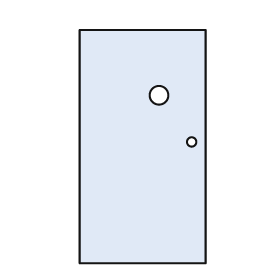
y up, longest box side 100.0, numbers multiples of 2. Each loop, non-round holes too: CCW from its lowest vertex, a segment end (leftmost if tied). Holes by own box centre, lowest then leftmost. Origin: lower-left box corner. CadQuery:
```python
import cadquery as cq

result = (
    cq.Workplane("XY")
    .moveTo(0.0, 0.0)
    .lineTo(54.0, 0.0)
    .lineTo(54.0, 100.0)
    .lineTo(0.0, 100.0)
    .close()
    .moveTo(48.0, 52.0)
    .circle(2.0)
    .moveTo(34.0, 72.0)
    .circle(4.0)
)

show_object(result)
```